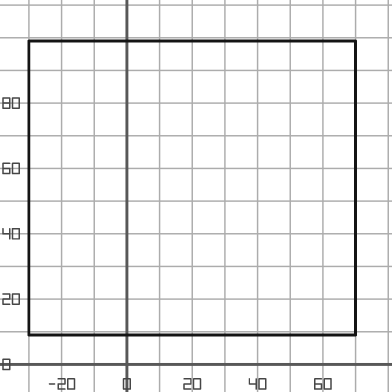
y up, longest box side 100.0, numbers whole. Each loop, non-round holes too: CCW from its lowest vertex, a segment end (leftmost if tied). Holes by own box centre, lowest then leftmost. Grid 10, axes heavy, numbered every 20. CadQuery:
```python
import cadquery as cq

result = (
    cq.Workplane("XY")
    .moveTo(-30.0, 9.0)
    .lineTo(70.0, 9.0)
    .lineTo(70.0, 99.0)
    .lineTo(-30.0, 99.0)
    .close()
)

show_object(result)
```